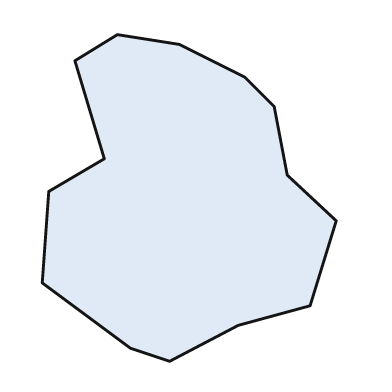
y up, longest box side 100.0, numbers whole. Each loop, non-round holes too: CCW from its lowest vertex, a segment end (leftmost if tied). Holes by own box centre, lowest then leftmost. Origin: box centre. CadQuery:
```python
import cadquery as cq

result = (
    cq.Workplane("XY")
    .moveTo(-6.0, -50.0)
    .lineTo(15.0, -39.0)
    .lineTo(37.0, -33.0)
    .lineTo(45.0, -7.0)
    .lineTo(30.0, 7.0)
    .lineTo(26.0, 28.0)
    .lineTo(17.0, 37.0)
    .lineTo(-3.0, 47.0)
    .lineTo(-22.0, 50.0)
    .lineTo(-35.0, 42.0)
    .lineTo(-26.0, 12.0)
    .lineTo(-43.0, 2.0)
    .lineTo(-45.0, -26.0)
    .lineTo(-18.0, -46.0)
    .close()
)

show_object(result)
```